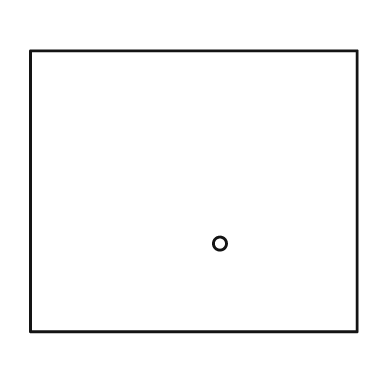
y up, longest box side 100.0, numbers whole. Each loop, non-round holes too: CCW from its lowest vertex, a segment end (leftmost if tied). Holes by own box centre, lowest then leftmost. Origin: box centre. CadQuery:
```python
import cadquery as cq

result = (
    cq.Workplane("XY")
    .moveTo(-50.0, -43.0)
    .lineTo(50.0, -43.0)
    .lineTo(50.0, 43.0)
    .lineTo(-50.0, 43.0)
    .close()
    .moveTo(8.0, -16.0)
    .circle(2.0)
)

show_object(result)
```